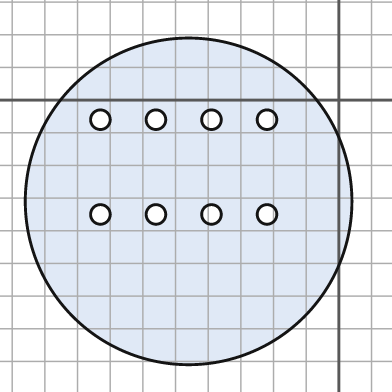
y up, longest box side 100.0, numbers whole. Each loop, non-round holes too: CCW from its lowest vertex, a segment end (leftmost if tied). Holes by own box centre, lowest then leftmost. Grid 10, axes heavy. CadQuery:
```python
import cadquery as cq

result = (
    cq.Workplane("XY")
    .moveTo(-46.0, -31.0)
    .circle(50.0)
    .moveTo(-73.0, -35.0)
    .circle(3.0)
    .moveTo(-56.0, -35.0)
    .circle(3.0)
    .moveTo(-39.0, -35.0)
    .circle(3.0)
    .moveTo(-22.0, -35.0)
    .circle(3.0)
    .moveTo(-73.0, -6.0)
    .circle(3.0)
    .moveTo(-56.0, -6.0)
    .circle(3.0)
    .moveTo(-39.0, -6.0)
    .circle(3.0)
    .moveTo(-22.0, -6.0)
    .circle(3.0)
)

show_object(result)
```